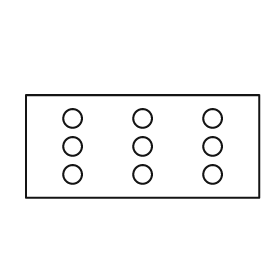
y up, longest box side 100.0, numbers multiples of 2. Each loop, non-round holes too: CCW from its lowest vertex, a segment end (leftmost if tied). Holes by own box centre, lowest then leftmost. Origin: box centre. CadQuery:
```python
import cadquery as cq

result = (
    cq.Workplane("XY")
    .moveTo(-50.0, -22.0)
    .lineTo(50.0, -22.0)
    .lineTo(50.0, 22.0)
    .lineTo(-50.0, 22.0)
    .close()
    .moveTo(-30.0, -12.0)
    .circle(4.0)
    .moveTo(0.0, -12.0)
    .circle(4.0)
    .moveTo(30.0, -12.0)
    .circle(4.0)
    .moveTo(-30.0, 0.0)
    .circle(4.0)
    .moveTo(0.0, 0.0)
    .circle(4.0)
    .moveTo(30.0, 0.0)
    .circle(4.0)
    .moveTo(-30.0, 12.0)
    .circle(4.0)
    .moveTo(0.0, 12.0)
    .circle(4.0)
    .moveTo(30.0, 12.0)
    .circle(4.0)
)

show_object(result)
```